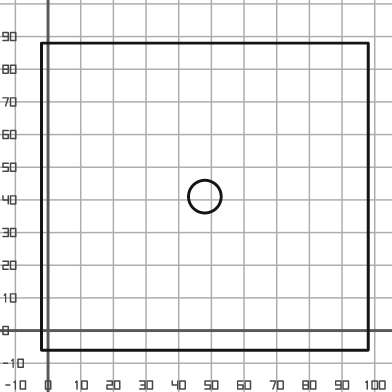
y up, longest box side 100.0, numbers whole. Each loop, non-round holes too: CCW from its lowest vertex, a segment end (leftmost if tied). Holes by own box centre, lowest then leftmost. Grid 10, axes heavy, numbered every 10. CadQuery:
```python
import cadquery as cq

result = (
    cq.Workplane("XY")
    .moveTo(-2.0, -6.0)
    .lineTo(98.0, -6.0)
    .lineTo(98.0, 88.0)
    .lineTo(-2.0, 88.0)
    .close()
    .moveTo(48.0, 41.0)
    .circle(5.0)
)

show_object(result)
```